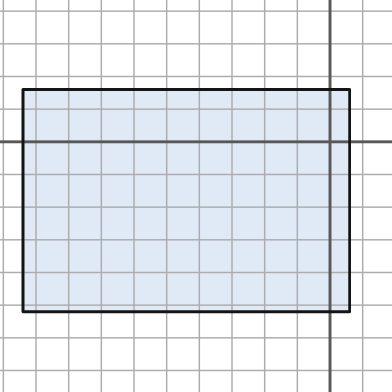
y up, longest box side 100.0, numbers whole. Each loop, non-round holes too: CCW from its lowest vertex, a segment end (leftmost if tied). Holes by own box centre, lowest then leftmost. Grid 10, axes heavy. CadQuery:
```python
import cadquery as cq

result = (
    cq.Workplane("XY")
    .moveTo(-94.0, -52.0)
    .lineTo(6.0, -52.0)
    .lineTo(6.0, 16.0)
    .lineTo(-94.0, 16.0)
    .close()
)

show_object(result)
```